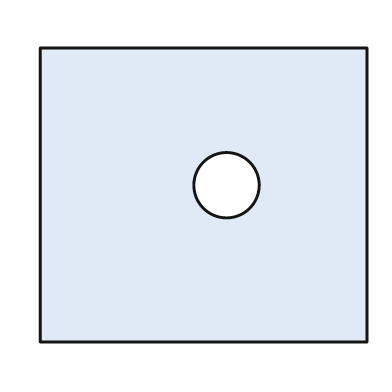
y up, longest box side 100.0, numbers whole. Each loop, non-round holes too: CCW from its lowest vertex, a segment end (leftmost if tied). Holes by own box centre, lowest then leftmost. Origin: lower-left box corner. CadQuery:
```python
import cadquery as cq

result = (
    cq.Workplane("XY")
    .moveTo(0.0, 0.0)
    .lineTo(100.0, 0.0)
    .lineTo(100.0, 90.0)
    .lineTo(0.0, 90.0)
    .close()
    .moveTo(57.0, 48.0)
    .circle(10.0)
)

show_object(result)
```